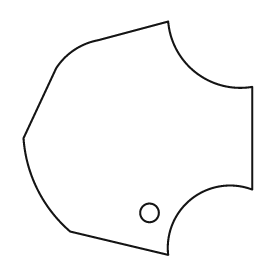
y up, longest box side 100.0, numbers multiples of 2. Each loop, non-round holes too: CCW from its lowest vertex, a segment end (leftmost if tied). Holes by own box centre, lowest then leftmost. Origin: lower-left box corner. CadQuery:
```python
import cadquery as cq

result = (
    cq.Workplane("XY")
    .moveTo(62.0, 0.0)
    .threePointArc((72.0, 24.0), (98.0, 28.0))
    .lineTo(98.0, 72.0)
    .threePointArc((74.0, 78.0), (62.0, 100.0))
    .lineTo(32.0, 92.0)
    .threePointArc((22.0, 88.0), (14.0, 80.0))
    .lineTo(0.0, 50.0)
    .threePointArc((6.0, 28.0), (20.0, 10.0))
    .close()
    .moveTo(54.0, 18.0)
    .circle(4.0)
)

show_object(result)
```